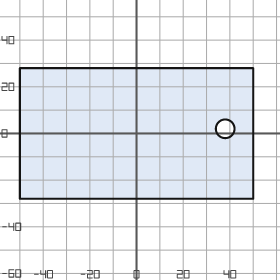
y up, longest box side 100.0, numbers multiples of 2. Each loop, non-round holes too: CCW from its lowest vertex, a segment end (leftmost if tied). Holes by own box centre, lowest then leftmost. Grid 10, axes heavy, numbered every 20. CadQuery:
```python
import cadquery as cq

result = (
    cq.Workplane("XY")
    .moveTo(-50.0, -28.0)
    .lineTo(50.0, -28.0)
    .lineTo(50.0, 28.0)
    .lineTo(-50.0, 28.0)
    .close()
    .moveTo(38.0, 2.0)
    .circle(4.0)
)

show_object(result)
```